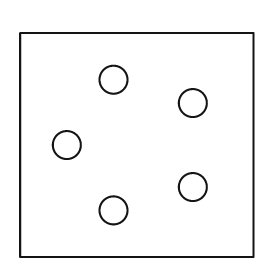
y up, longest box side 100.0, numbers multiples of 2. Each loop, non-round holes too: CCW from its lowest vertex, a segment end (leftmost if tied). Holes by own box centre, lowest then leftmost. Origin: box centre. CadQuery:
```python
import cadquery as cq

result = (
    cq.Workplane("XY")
    .moveTo(-50.0, -48.0)
    .lineTo(50.0, -48.0)
    .lineTo(50.0, 48.0)
    .lineTo(-50.0, 48.0)
    .close()
    .moveTo(-10.0, -28.0)
    .circle(6.0)
    .moveTo(24.0, -18.0)
    .circle(6.0)
    .moveTo(-30.0, 0.0)
    .circle(6.0)
    .moveTo(24.0, 18.0)
    .circle(6.0)
    .moveTo(-10.0, 28.0)
    .circle(6.0)
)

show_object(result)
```